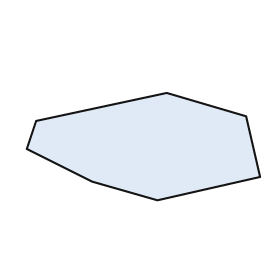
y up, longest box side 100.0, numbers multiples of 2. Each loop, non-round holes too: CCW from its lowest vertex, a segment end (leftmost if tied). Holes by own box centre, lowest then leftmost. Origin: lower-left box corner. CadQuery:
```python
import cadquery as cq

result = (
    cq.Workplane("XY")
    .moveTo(56.0, 0.0)
    .lineTo(100.0, 10.0)
    .lineTo(94.0, 36.0)
    .lineTo(60.0, 46.0)
    .lineTo(4.0, 34.0)
    .lineTo(0.0, 22.0)
    .lineTo(28.0, 8.0)
    .close()
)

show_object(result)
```